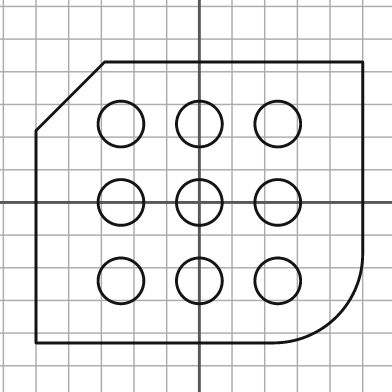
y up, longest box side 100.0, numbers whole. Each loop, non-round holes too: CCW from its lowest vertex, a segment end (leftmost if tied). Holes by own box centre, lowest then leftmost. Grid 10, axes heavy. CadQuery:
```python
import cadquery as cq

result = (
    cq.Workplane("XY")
    .moveTo(-50.0, -43.0)
    .lineTo(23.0, -43.0)
    .threePointArc((42.0, -35.0), (50.0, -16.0))
    .lineTo(50.0, 43.0)
    .lineTo(-29.0, 43.0)
    .lineTo(-50.0, 22.0)
    .close()
    .moveTo(-24.0, -24.0)
    .circle(7.0)
    .moveTo(0.0, -24.0)
    .circle(7.0)
    .moveTo(24.0, -24.0)
    .circle(7.0)
    .moveTo(-24.0, 0.0)
    .circle(7.0)
    .moveTo(0.0, 0.0)
    .circle(7.0)
    .moveTo(24.0, 0.0)
    .circle(7.0)
    .moveTo(-24.0, 24.0)
    .circle(7.0)
    .moveTo(0.0, 24.0)
    .circle(7.0)
    .moveTo(24.0, 24.0)
    .circle(7.0)
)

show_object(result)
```